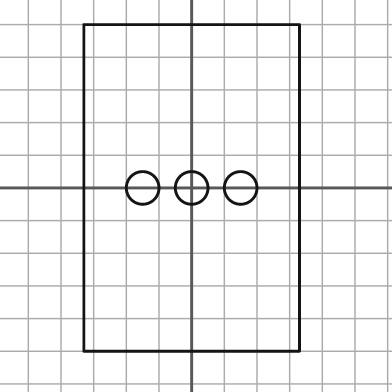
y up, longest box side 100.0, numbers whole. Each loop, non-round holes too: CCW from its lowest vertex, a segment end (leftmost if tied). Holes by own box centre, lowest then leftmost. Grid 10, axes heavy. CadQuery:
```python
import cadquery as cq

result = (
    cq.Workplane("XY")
    .moveTo(-33.0, -50.0)
    .lineTo(33.0, -50.0)
    .lineTo(33.0, 50.0)
    .lineTo(-33.0, 50.0)
    .close()
    .moveTo(-15.0, 0.0)
    .circle(5.0)
    .moveTo(0.0, 0.0)
    .circle(5.0)
    .moveTo(15.0, 0.0)
    .circle(5.0)
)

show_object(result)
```